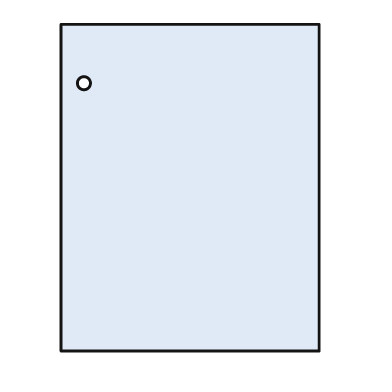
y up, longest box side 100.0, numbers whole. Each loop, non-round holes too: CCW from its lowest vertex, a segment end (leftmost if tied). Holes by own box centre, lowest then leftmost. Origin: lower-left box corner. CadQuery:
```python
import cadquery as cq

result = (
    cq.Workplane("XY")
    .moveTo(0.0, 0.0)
    .lineTo(79.0, 0.0)
    .lineTo(79.0, 100.0)
    .lineTo(0.0, 100.0)
    .close()
    .moveTo(7.0, 82.0)
    .circle(2.0)
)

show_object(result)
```